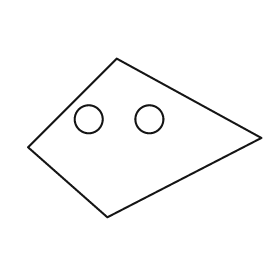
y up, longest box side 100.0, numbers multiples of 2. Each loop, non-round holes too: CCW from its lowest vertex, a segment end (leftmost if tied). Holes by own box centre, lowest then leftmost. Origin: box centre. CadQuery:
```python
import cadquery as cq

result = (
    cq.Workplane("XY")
    .moveTo(-16.0, -34.0)
    .lineTo(50.0, 0.0)
    .lineTo(-12.0, 34.0)
    .lineTo(-50.0, -4.0)
    .close()
    .moveTo(-24.0, 8.0)
    .circle(6.0)
    .moveTo(2.0, 8.0)
    .circle(6.0)
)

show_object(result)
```